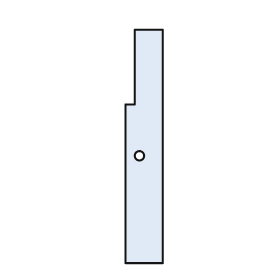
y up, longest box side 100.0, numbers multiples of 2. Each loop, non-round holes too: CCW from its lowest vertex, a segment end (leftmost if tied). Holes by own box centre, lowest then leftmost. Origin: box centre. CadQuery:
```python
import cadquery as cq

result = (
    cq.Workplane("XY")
    .moveTo(-8.0, -50.0)
    .lineTo(8.0, -50.0)
    .lineTo(8.0, 50.0)
    .lineTo(-4.0, 50.0)
    .lineTo(-4.0, 18.0)
    .lineTo(-8.0, 18.0)
    .close()
    .moveTo(-2.0, -4.0)
    .circle(2.0)
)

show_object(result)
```